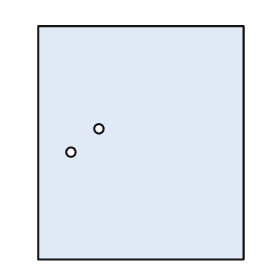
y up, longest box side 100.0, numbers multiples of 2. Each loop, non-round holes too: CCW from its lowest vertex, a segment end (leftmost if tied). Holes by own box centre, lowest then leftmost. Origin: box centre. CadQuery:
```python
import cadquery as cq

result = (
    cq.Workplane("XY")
    .moveTo(-44.0, -50.0)
    .lineTo(44.0, -50.0)
    .lineTo(44.0, 50.0)
    .lineTo(-44.0, 50.0)
    .close()
    .moveTo(-30.0, -4.0)
    .circle(2.0)
    .moveTo(-18.0, 6.0)
    .circle(2.0)
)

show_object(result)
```